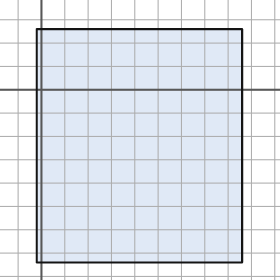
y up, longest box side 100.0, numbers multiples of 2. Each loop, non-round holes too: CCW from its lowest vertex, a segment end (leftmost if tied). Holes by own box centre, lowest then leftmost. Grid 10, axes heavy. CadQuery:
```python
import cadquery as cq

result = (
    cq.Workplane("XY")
    .moveTo(-2.0, -74.0)
    .lineTo(86.0, -74.0)
    .lineTo(86.0, 26.0)
    .lineTo(-2.0, 26.0)
    .close()
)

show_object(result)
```